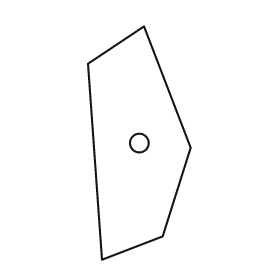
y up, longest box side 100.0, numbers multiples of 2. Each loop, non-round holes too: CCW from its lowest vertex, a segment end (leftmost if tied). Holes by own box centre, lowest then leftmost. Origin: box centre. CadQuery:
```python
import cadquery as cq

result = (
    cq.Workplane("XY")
    .moveTo(-16.0, -50.0)
    .lineTo(10.0, -40.0)
    .lineTo(22.0, -2.0)
    .lineTo(2.0, 50.0)
    .lineTo(-22.0, 34.0)
    .close()
    .moveTo(0.0, 0.0)
    .circle(4.0)
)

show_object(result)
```